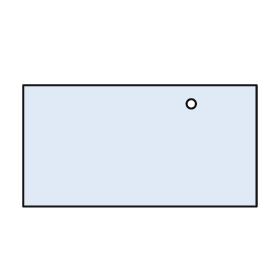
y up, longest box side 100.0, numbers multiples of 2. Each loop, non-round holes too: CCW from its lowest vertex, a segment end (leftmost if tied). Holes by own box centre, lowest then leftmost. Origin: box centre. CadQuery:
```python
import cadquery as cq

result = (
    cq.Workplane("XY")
    .moveTo(-50.0, -26.0)
    .lineTo(50.0, -26.0)
    .lineTo(50.0, 26.0)
    .lineTo(-50.0, 26.0)
    .close()
    .moveTo(22.0, 18.0)
    .circle(2.0)
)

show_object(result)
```